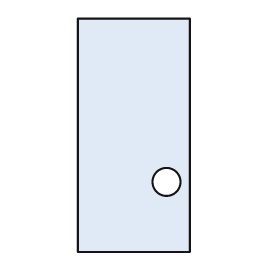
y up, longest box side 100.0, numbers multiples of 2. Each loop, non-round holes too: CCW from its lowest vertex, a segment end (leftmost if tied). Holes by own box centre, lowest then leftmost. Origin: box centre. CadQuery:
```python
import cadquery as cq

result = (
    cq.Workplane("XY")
    .moveTo(-24.0, -50.0)
    .lineTo(24.0, -50.0)
    .lineTo(24.0, 50.0)
    .lineTo(-24.0, 50.0)
    .close()
    .moveTo(14.0, -20.0)
    .circle(6.0)
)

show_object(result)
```